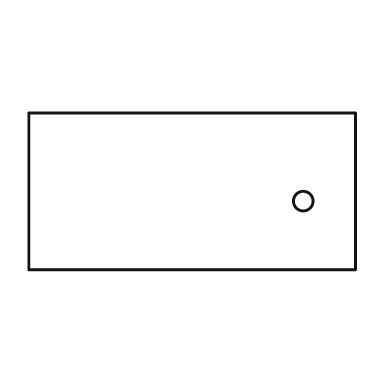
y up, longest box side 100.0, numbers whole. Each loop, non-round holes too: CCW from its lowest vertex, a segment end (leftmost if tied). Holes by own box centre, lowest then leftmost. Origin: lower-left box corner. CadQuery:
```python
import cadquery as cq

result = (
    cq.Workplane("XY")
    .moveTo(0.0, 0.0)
    .lineTo(100.0, 0.0)
    .lineTo(100.0, 48.0)
    .lineTo(0.0, 48.0)
    .close()
    .moveTo(84.0, 21.0)
    .circle(3.0)
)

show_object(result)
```